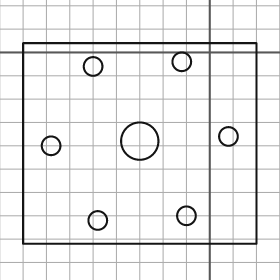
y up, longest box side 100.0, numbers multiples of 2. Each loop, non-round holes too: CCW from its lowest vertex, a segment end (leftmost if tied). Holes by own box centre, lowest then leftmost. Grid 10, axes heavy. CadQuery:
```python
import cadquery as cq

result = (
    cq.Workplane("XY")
    .moveTo(-80.0, -82.0)
    .lineTo(20.0, -82.0)
    .lineTo(20.0, 4.0)
    .lineTo(-80.0, 4.0)
    .close()
    .moveTo(-48.0, -72.0)
    .circle(4.0)
    .moveTo(-10.0, -70.0)
    .circle(4.0)
    .moveTo(-68.0, -40.0)
    .circle(4.0)
    .moveTo(-30.0, -38.0)
    .circle(8.0)
    .moveTo(8.0, -36.0)
    .circle(4.0)
    .moveTo(-50.0, -6.0)
    .circle(4.0)
    .moveTo(-12.0, -4.0)
    .circle(4.0)
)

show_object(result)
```